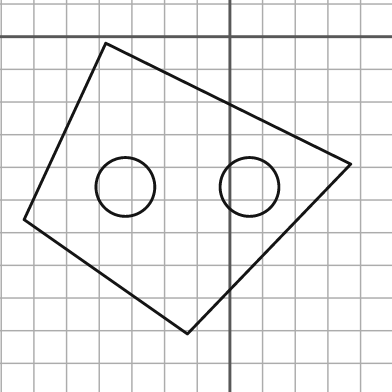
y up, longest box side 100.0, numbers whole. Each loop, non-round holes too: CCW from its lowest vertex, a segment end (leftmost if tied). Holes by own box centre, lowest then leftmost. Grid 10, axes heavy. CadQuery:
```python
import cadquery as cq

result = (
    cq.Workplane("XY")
    .moveTo(-13.0, -91.0)
    .lineTo(37.0, -39.0)
    .lineTo(-38.0, -2.0)
    .lineTo(-63.0, -56.0)
    .close()
    .moveTo(-32.0, -46.0)
    .circle(9.0)
    .moveTo(6.0, -46.0)
    .circle(9.0)
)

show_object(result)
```